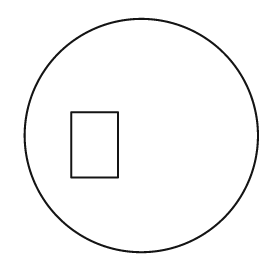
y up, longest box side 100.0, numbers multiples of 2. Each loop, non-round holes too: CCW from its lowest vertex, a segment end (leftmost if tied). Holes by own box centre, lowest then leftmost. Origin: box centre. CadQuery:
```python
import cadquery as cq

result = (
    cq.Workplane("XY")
    .moveTo(0.0, 0.0)
    .circle(50.0)
    .moveTo(-30.0, -18.0)
    .lineTo(-10.0, -18.0)
    .lineTo(-10.0, 10.0)
    .lineTo(-30.0, 10.0)
    .close()
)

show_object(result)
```